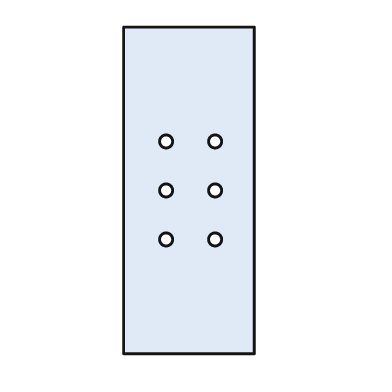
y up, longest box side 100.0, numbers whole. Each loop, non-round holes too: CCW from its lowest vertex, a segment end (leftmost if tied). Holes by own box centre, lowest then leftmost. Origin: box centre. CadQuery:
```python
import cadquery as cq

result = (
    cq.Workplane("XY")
    .moveTo(-20.0, -50.0)
    .lineTo(20.0, -50.0)
    .lineTo(20.0, 50.0)
    .lineTo(-20.0, 50.0)
    .close()
    .moveTo(-7.0, -15.0)
    .circle(2.0)
    .moveTo(8.0, -15.0)
    .circle(2.0)
    .moveTo(-7.0, 0.0)
    .circle(2.0)
    .moveTo(8.0, 0.0)
    .circle(2.0)
    .moveTo(-7.0, 15.0)
    .circle(2.0)
    .moveTo(8.0, 15.0)
    .circle(2.0)
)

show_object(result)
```